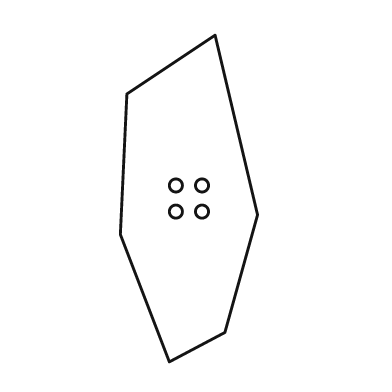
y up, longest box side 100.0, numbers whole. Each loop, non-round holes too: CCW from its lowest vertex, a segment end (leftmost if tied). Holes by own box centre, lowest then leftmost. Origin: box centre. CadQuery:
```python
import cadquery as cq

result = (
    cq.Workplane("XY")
    .moveTo(-6.0, -50.0)
    .lineTo(11.0, -41.0)
    .lineTo(21.0, -5.0)
    .lineTo(8.0, 50.0)
    .lineTo(-19.0, 32.0)
    .lineTo(-21.0, -11.0)
    .close()
    .moveTo(-4.0, -4.0)
    .circle(2.0)
    .moveTo(4.0, -4.0)
    .circle(2.0)
    .moveTo(-4.0, 4.0)
    .circle(2.0)
    .moveTo(4.0, 4.0)
    .circle(2.0)
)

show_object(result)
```